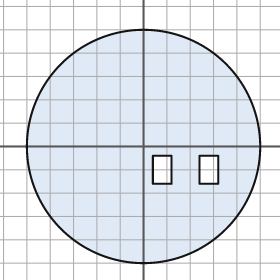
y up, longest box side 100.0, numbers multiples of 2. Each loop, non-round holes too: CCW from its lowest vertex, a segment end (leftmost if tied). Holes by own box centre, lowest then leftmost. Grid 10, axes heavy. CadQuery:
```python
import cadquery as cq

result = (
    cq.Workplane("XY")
    .moveTo(0.0, 0.0)
    .circle(50.0)
    .moveTo(4.0, -16.0)
    .lineTo(12.0, -16.0)
    .lineTo(12.0, -4.0)
    .lineTo(4.0, -4.0)
    .close()
    .moveTo(24.0, -16.0)
    .lineTo(32.0, -16.0)
    .lineTo(32.0, -4.0)
    .lineTo(24.0, -4.0)
    .close()
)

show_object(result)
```